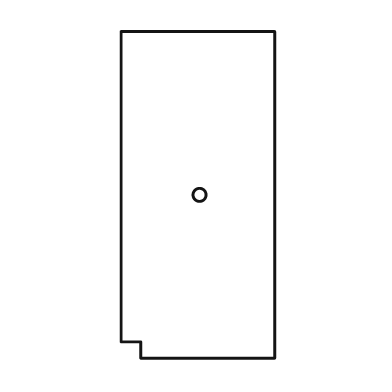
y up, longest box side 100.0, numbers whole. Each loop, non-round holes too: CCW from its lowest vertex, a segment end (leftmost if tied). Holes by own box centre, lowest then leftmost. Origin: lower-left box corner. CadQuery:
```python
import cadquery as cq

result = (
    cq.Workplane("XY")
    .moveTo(6.0, 0.0)
    .lineTo(47.0, 0.0)
    .lineTo(47.0, 100.0)
    .lineTo(0.0, 100.0)
    .lineTo(0.0, 5.0)
    .lineTo(6.0, 5.0)
    .close()
    .moveTo(24.0, 50.0)
    .circle(2.0)
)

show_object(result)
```